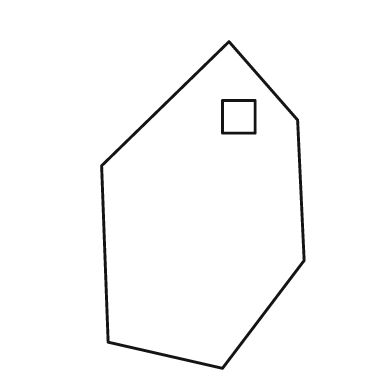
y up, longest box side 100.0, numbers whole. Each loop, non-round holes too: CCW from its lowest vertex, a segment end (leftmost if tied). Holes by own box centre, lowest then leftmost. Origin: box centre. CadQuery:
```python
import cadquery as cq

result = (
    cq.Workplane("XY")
    .moveTo(6.0, -50.0)
    .lineTo(31.0, -17.0)
    .lineTo(29.0, 26.0)
    .lineTo(8.0, 50.0)
    .lineTo(-31.0, 12.0)
    .lineTo(-29.0, -42.0)
    .close()
    .moveTo(6.0, 22.0)
    .lineTo(16.0, 22.0)
    .lineTo(16.0, 32.0)
    .lineTo(6.0, 32.0)
    .close()
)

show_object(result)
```